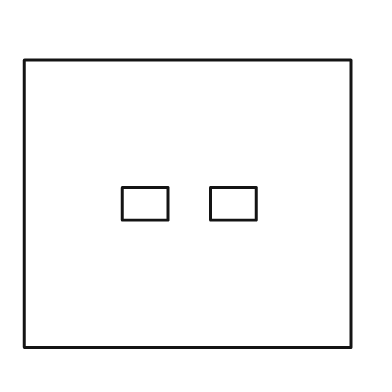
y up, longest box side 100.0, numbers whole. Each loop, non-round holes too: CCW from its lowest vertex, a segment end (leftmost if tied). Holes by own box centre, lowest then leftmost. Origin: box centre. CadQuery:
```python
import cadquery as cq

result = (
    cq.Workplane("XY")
    .moveTo(-50.0, -44.0)
    .lineTo(50.0, -44.0)
    .lineTo(50.0, 44.0)
    .lineTo(-50.0, 44.0)
    .close()
    .moveTo(-20.0, -5.0)
    .lineTo(-6.0, -5.0)
    .lineTo(-6.0, 5.0)
    .lineTo(-20.0, 5.0)
    .close()
    .moveTo(7.0, -5.0)
    .lineTo(21.0, -5.0)
    .lineTo(21.0, 5.0)
    .lineTo(7.0, 5.0)
    .close()
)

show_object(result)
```